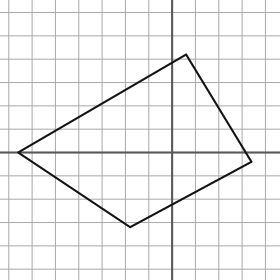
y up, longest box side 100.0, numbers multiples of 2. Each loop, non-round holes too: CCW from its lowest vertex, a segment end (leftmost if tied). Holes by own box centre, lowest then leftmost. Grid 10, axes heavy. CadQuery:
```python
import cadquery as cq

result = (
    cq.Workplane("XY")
    .moveTo(-18.0, -32.0)
    .lineTo(34.0, -4.0)
    .lineTo(6.0, 42.0)
    .lineTo(-66.0, 0.0)
    .close()
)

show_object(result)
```